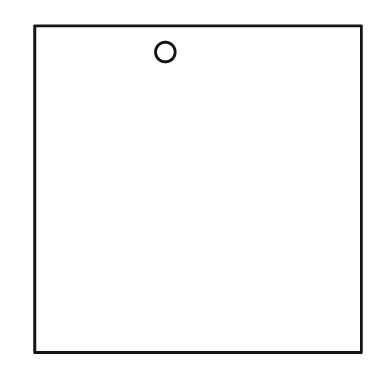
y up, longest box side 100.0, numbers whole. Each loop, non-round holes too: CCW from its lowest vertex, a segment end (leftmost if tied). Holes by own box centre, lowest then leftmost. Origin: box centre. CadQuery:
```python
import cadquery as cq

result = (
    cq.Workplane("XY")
    .moveTo(-50.0, -50.0)
    .lineTo(50.0, -50.0)
    .lineTo(50.0, 50.0)
    .lineTo(-50.0, 50.0)
    .close()
    .moveTo(-10.0, 42.0)
    .circle(3.0)
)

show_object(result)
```